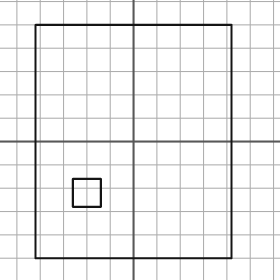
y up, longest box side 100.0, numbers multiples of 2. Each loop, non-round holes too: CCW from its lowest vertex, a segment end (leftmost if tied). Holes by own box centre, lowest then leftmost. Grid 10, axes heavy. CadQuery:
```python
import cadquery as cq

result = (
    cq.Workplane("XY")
    .moveTo(-42.0, -50.0)
    .lineTo(42.0, -50.0)
    .lineTo(42.0, 50.0)
    .lineTo(-42.0, 50.0)
    .close()
    .moveTo(-26.0, -28.0)
    .lineTo(-14.0, -28.0)
    .lineTo(-14.0, -16.0)
    .lineTo(-26.0, -16.0)
    .close()
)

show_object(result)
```